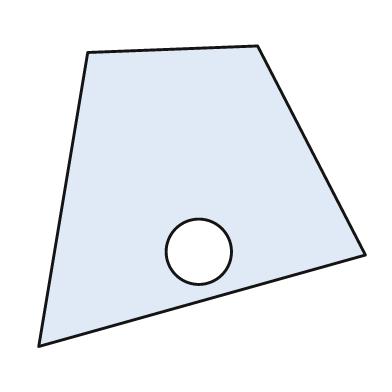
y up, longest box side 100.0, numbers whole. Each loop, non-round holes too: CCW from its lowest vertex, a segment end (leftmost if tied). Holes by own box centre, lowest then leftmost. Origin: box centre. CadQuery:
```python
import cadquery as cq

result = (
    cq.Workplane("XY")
    .moveTo(-50.0, -46.0)
    .lineTo(50.0, -18.0)
    .lineTo(17.0, 46.0)
    .lineTo(-35.0, 44.0)
    .close()
    .moveTo(-1.0, -17.0)
    .circle(10.0)
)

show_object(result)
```